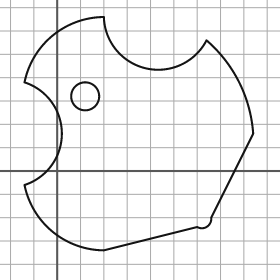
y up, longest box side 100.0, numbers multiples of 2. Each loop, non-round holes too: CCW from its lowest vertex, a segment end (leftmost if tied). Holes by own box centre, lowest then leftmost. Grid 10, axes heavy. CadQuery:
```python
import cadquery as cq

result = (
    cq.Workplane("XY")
    .moveTo(20.0, -34.0)
    .lineTo(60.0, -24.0)
    .threePointArc((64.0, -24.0), (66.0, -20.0))
    .lineTo(84.0, 16.0)
    .threePointArc((78.0, 38.0), (64.0, 56.0))
    .threePointArc((38.0, 44.0), (20.0, 66.0))
    .threePointArc((-2.0, 58.0), (-14.0, 38.0))
    .threePointArc((2.0, 16.0), (-14.0, -6.0))
    .threePointArc((-2.0, -26.0), (20.0, -34.0))
    .close()
    .moveTo(12.0, 32.0)
    .circle(6.0)
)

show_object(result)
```